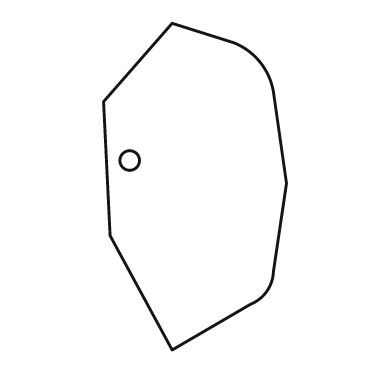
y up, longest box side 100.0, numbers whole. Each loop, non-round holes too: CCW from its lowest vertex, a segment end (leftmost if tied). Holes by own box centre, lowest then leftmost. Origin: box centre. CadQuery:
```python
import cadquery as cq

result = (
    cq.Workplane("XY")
    .moveTo(-7.0, -50.0)
    .lineTo(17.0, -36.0)
    .threePointArc((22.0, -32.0), (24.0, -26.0))
    .lineTo(28.0, 1.0)
    .lineTo(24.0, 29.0)
    .threePointArc((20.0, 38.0), (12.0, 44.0))
    .lineTo(-7.0, 50.0)
    .lineTo(-28.0, 26.0)
    .lineTo(-26.0, -15.0)
    .close()
    .moveTo(-20.0, 8.0)
    .circle(3.0)
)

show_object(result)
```